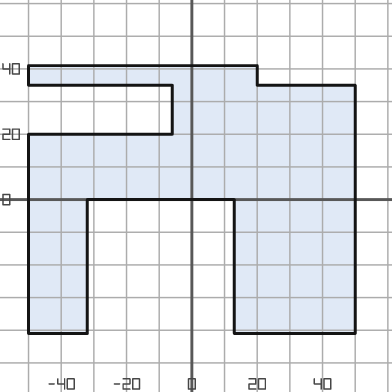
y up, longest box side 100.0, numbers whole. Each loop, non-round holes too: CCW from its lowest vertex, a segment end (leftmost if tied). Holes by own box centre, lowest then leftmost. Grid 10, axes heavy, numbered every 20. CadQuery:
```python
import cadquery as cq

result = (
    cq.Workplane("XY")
    .moveTo(-50.0, -41.0)
    .lineTo(-32.0, -41.0)
    .lineTo(-32.0, 0.0)
    .lineTo(13.0, 0.0)
    .lineTo(13.0, -41.0)
    .lineTo(50.0, -41.0)
    .lineTo(50.0, 35.0)
    .lineTo(20.0, 35.0)
    .lineTo(20.0, 41.0)
    .lineTo(-50.0, 41.0)
    .lineTo(-50.0, 35.0)
    .lineTo(-6.0, 35.0)
    .lineTo(-6.0, 20.0)
    .lineTo(-50.0, 20.0)
    .close()
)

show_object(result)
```